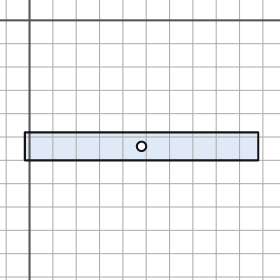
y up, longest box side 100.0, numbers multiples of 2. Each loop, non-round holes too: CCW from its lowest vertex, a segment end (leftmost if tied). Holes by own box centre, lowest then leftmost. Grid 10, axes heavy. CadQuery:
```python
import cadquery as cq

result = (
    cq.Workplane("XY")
    .moveTo(-2.0, -60.0)
    .lineTo(98.0, -60.0)
    .lineTo(98.0, -48.0)
    .lineTo(-2.0, -48.0)
    .close()
    .moveTo(48.0, -54.0)
    .circle(2.0)
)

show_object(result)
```